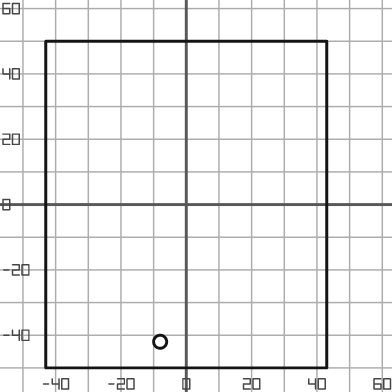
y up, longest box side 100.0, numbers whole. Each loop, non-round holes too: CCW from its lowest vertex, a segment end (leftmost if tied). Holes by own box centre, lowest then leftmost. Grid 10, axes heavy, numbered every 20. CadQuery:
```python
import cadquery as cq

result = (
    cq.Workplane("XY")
    .moveTo(-43.0, -50.0)
    .lineTo(43.0, -50.0)
    .lineTo(43.0, 50.0)
    .lineTo(-43.0, 50.0)
    .close()
    .moveTo(-8.0, -42.0)
    .circle(2.0)
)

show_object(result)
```